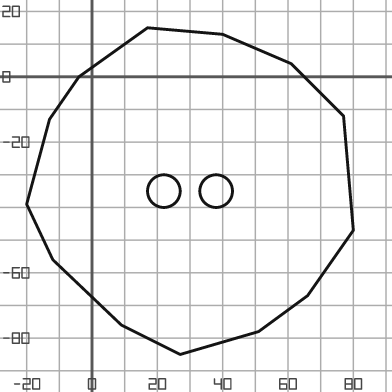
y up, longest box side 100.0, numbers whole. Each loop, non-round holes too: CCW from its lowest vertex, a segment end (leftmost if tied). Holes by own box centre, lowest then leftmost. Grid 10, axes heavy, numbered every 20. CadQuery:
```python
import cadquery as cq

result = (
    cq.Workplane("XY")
    .moveTo(27.0, -85.0)
    .lineTo(51.0, -78.0)
    .lineTo(66.0, -67.0)
    .lineTo(80.0, -47.0)
    .lineTo(77.0, -12.0)
    .lineTo(61.0, 4.0)
    .lineTo(40.0, 13.0)
    .lineTo(17.0, 15.0)
    .lineTo(-4.0, 0.0)
    .lineTo(-13.0, -13.0)
    .lineTo(-20.0, -39.0)
    .lineTo(-12.0, -56.0)
    .lineTo(9.0, -76.0)
    .close()
    .moveTo(22.0, -35.0)
    .circle(5.0)
    .moveTo(38.0, -35.0)
    .circle(5.0)
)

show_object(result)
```